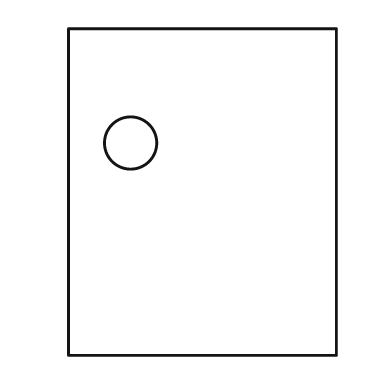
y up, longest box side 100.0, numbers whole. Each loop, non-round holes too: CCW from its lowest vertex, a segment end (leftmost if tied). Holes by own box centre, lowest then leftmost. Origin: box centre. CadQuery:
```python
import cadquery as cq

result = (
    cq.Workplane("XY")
    .moveTo(-41.0, -50.0)
    .lineTo(41.0, -50.0)
    .lineTo(41.0, 50.0)
    .lineTo(-41.0, 50.0)
    .close()
    .moveTo(-22.0, 15.0)
    .circle(8.0)
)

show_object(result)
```